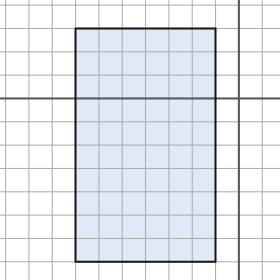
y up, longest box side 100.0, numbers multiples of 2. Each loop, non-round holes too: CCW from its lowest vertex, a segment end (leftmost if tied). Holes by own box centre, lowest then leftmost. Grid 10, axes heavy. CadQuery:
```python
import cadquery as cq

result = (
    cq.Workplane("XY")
    .moveTo(-70.0, -70.0)
    .lineTo(-10.0, -70.0)
    .lineTo(-10.0, 30.0)
    .lineTo(-70.0, 30.0)
    .close()
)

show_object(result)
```